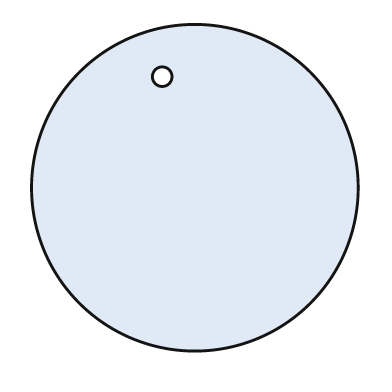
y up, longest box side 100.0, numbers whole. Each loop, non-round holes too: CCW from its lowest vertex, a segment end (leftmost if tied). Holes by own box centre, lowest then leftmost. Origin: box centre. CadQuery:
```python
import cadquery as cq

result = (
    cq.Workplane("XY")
    .moveTo(0.0, 0.0)
    .circle(50.0)
    .moveTo(-10.0, 34.0)
    .circle(3.0)
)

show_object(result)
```